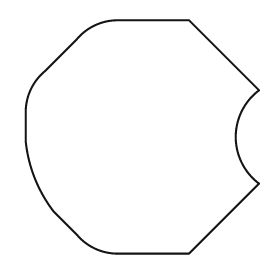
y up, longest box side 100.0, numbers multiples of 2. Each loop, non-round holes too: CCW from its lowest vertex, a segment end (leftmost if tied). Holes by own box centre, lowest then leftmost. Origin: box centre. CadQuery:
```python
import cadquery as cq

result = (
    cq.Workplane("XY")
    .moveTo(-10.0, -50.0)
    .lineTo(20.0, -50.0)
    .lineTo(50.0, -20.0)
    .threePointArc((40.0, 0.0), (50.0, 20.0))
    .lineTo(20.0, 50.0)
    .lineTo(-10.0, 50.0)
    .threePointArc((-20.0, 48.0), (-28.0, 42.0))
    .lineTo(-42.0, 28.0)
    .threePointArc((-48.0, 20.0), (-50.0, 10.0))
    .lineTo(-50.0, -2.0)
    .threePointArc((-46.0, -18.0), (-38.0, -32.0))
    .lineTo(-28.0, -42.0)
    .threePointArc((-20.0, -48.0), (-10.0, -50.0))
    .close()
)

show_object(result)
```